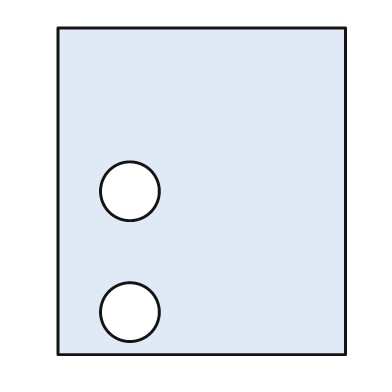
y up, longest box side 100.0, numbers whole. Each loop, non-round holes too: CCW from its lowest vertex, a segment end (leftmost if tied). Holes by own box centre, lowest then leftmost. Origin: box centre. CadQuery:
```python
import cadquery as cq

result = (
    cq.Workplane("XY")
    .moveTo(-44.0, -50.0)
    .lineTo(44.0, -50.0)
    .lineTo(44.0, 50.0)
    .lineTo(-44.0, 50.0)
    .close()
    .moveTo(-22.0, -37.0)
    .circle(9.0)
    .moveTo(-22.0, 0.0)
    .circle(9.0)
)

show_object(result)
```